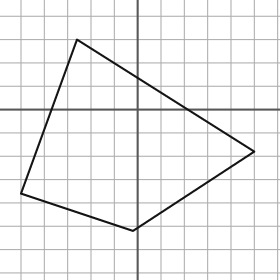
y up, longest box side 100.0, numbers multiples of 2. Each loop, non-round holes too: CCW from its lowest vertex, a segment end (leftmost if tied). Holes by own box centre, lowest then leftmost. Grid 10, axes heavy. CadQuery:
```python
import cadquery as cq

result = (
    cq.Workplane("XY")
    .moveTo(-2.0, -52.0)
    .lineTo(50.0, -18.0)
    .lineTo(-26.0, 30.0)
    .lineTo(-50.0, -36.0)
    .close()
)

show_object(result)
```